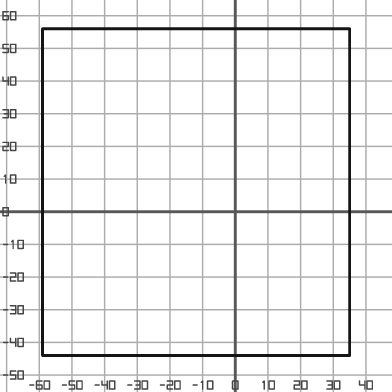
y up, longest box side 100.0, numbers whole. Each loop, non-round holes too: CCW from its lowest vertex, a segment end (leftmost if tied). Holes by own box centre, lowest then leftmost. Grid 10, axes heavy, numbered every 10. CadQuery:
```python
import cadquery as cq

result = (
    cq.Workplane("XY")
    .moveTo(-59.0, -44.0)
    .lineTo(35.0, -44.0)
    .lineTo(35.0, 56.0)
    .lineTo(-59.0, 56.0)
    .close()
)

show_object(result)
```